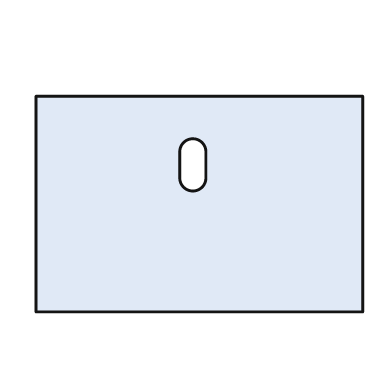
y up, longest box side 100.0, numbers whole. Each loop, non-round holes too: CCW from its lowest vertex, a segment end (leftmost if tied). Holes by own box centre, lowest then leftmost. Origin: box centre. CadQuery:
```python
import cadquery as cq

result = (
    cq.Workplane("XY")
    .moveTo(-50.0, -33.0)
    .lineTo(50.0, -33.0)
    .lineTo(50.0, 33.0)
    .lineTo(-50.0, 33.0)
    .close()
    .moveTo(-6.0, 8.0)
    .threePointArc((-2.0, 4.0), (2.0, 8.0))
    .lineTo(2.0, 16.0)
    .threePointArc((-2.0, 20.0), (-6.0, 16.0))
    .close()
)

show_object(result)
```